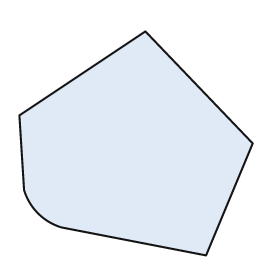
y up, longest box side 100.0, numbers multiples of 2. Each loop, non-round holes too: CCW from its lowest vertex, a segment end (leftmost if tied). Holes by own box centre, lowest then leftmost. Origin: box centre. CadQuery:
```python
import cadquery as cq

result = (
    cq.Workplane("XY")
    .moveTo(30.0, -48.0)
    .lineTo(50.0, 0.0)
    .lineTo(4.0, 48.0)
    .lineTo(-50.0, 12.0)
    .lineTo(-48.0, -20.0)
    .threePointArc((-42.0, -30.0), (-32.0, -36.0))
    .close()
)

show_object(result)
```